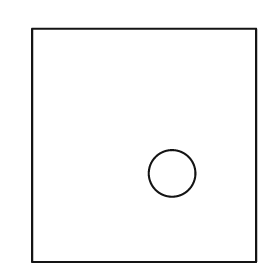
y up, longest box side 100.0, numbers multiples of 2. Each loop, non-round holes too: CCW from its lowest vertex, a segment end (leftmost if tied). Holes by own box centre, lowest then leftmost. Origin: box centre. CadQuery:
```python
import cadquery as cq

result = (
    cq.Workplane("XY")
    .moveTo(-48.0, -50.0)
    .lineTo(48.0, -50.0)
    .lineTo(48.0, 50.0)
    .lineTo(-48.0, 50.0)
    .close()
    .moveTo(12.0, -12.0)
    .circle(10.0)
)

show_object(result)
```